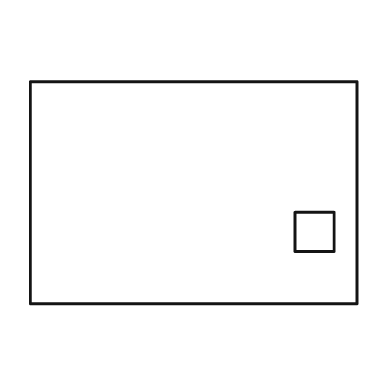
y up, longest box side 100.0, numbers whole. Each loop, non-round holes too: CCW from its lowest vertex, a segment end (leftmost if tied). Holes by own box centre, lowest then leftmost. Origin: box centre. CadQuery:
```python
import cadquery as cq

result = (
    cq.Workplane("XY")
    .moveTo(-50.0, -34.0)
    .lineTo(50.0, -34.0)
    .lineTo(50.0, 34.0)
    .lineTo(-50.0, 34.0)
    .close()
    .moveTo(31.0, -18.0)
    .lineTo(43.0, -18.0)
    .lineTo(43.0, -6.0)
    .lineTo(31.0, -6.0)
    .close()
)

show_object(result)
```